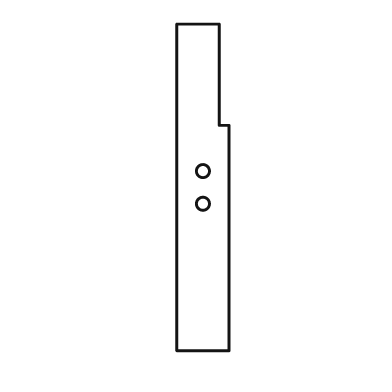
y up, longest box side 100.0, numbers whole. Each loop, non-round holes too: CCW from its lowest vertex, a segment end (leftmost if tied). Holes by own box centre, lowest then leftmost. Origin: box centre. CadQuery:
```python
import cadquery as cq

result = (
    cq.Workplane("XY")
    .moveTo(-8.0, -50.0)
    .lineTo(8.0, -50.0)
    .lineTo(8.0, 19.0)
    .lineTo(5.0, 19.0)
    .lineTo(5.0, 50.0)
    .lineTo(-8.0, 50.0)
    .close()
    .moveTo(0.0, -5.0)
    .circle(2.0)
    .moveTo(0.0, 5.0)
    .circle(2.0)
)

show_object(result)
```